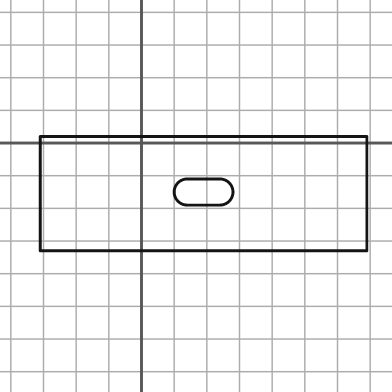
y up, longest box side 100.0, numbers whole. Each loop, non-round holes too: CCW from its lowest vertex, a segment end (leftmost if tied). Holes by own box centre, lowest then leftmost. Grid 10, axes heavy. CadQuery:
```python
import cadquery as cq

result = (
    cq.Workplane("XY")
    .moveTo(-31.0, -33.0)
    .lineTo(69.0, -33.0)
    .lineTo(69.0, 2.0)
    .lineTo(-31.0, 2.0)
    .close()
    .moveTo(14.0, -19.0)
    .lineTo(24.0, -19.0)
    .threePointArc((28.0, -15.0), (24.0, -11.0))
    .lineTo(14.0, -11.0)
    .threePointArc((10.0, -15.0), (14.0, -19.0))
    .close()
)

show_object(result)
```